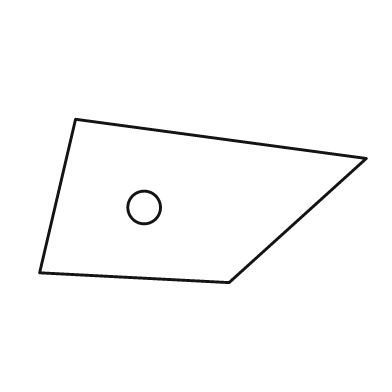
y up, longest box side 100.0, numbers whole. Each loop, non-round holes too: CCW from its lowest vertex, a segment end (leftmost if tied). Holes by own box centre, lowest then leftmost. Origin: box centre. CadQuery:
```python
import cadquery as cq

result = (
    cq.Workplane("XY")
    .moveTo(8.0, -25.0)
    .lineTo(50.0, 13.0)
    .lineTo(-39.0, 25.0)
    .lineTo(-50.0, -22.0)
    .close()
    .moveTo(-18.0, -2.0)
    .circle(5.0)
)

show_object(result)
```